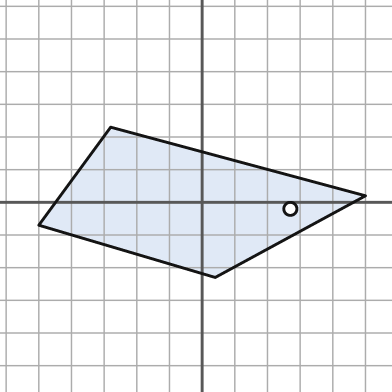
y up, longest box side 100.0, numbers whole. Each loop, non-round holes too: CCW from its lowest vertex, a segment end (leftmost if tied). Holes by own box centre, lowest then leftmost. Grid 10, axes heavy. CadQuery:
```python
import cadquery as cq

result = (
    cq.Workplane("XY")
    .moveTo(4.0, -23.0)
    .lineTo(50.0, 2.0)
    .lineTo(-28.0, 23.0)
    .lineTo(-50.0, -7.0)
    .close()
    .moveTo(27.0, -2.0)
    .circle(2.0)
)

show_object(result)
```